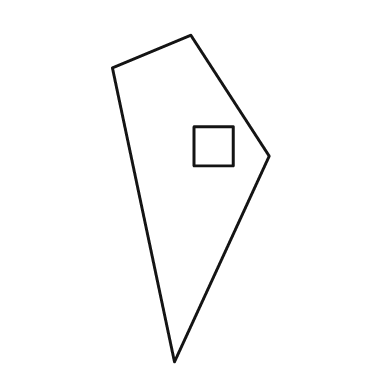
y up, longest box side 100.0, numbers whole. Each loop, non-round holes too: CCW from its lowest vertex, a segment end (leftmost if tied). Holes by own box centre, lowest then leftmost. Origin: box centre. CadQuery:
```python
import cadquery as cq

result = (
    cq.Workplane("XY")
    .moveTo(-5.0, -50.0)
    .lineTo(24.0, 13.0)
    .lineTo(0.0, 50.0)
    .lineTo(-24.0, 40.0)
    .close()
    .moveTo(1.0, 10.0)
    .lineTo(13.0, 10.0)
    .lineTo(13.0, 22.0)
    .lineTo(1.0, 22.0)
    .close()
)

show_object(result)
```